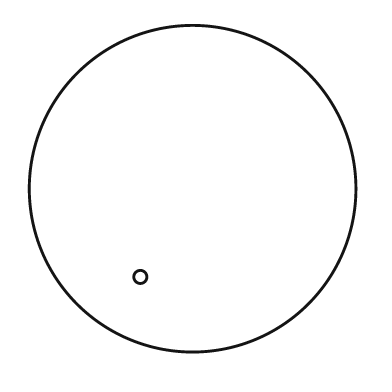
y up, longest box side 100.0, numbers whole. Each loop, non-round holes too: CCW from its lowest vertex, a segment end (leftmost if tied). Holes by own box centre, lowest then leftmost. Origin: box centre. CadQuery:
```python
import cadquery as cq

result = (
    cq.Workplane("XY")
    .moveTo(0.0, 0.0)
    .circle(50.0)
    .moveTo(-16.0, -27.0)
    .circle(2.0)
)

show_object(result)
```